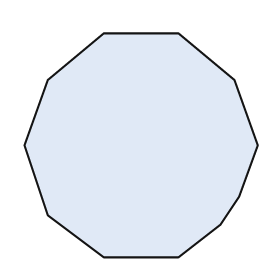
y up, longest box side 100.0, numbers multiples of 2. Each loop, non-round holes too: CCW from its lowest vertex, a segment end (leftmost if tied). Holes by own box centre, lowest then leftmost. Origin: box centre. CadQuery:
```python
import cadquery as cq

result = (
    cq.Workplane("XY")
    .moveTo(-16.0, -48.0)
    .lineTo(16.0, -48.0)
    .lineTo(34.0, -34.0)
    .lineTo(42.0, -22.0)
    .lineTo(50.0, 0.0)
    .lineTo(40.0, 28.0)
    .lineTo(16.0, 48.0)
    .lineTo(-16.0, 48.0)
    .lineTo(-40.0, 28.0)
    .lineTo(-50.0, 0.0)
    .lineTo(-40.0, -30.0)
    .close()
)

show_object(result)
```